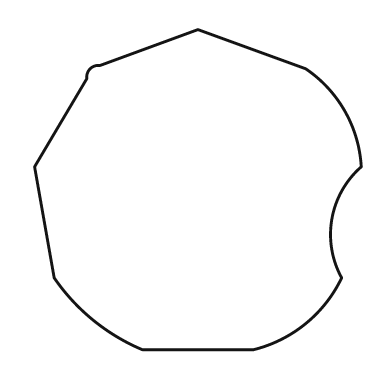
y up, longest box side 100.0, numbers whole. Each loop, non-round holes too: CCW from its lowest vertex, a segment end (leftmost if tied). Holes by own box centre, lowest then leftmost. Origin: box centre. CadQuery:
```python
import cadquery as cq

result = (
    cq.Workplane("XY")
    .moveTo(-17.0, -49.0)
    .lineTo(17.0, -49.0)
    .threePointArc((33.0, -41.0), (44.0, -27.0))
    .threePointArc((41.0, -9.0), (50.0, 7.0))
    .threePointArc((45.0, 24.0), (33.0, 37.0))
    .lineTo(0.0, 49.0)
    .lineTo(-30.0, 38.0)
    .threePointArc((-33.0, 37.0), (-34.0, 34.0))
    .lineTo(-50.0, 7.0)
    .lineTo(-44.0, -27.0)
    .threePointArc((-32.0, -40.0), (-17.0, -49.0))
    .close()
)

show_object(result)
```